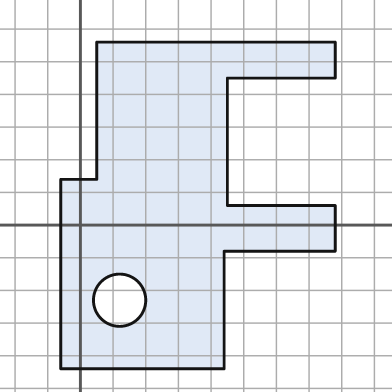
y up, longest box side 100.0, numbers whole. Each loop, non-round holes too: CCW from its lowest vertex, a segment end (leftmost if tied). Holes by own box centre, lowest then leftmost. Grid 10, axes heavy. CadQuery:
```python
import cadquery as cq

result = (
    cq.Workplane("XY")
    .moveTo(-6.0, -44.0)
    .lineTo(44.0, -44.0)
    .lineTo(44.0, -8.0)
    .lineTo(78.0, -8.0)
    .lineTo(78.0, 6.0)
    .lineTo(45.0, 6.0)
    .lineTo(45.0, 45.0)
    .lineTo(78.0, 45.0)
    .lineTo(78.0, 56.0)
    .lineTo(5.0, 56.0)
    .lineTo(5.0, 14.0)
    .lineTo(-6.0, 14.0)
    .close()
    .moveTo(12.0, -23.0)
    .circle(8.0)
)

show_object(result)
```